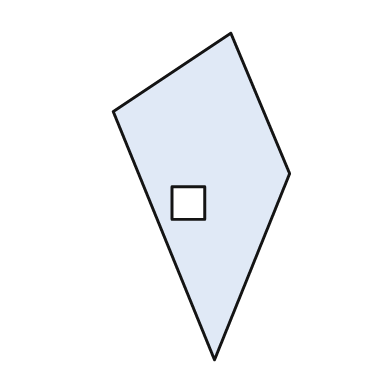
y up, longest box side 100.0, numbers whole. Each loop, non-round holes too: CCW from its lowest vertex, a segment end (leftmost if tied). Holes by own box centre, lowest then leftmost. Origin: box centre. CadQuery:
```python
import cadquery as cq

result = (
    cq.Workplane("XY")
    .moveTo(4.0, -50.0)
    .lineTo(27.0, 7.0)
    .lineTo(9.0, 50.0)
    .lineTo(-27.0, 26.0)
    .close()
    .moveTo(-9.0, -7.0)
    .lineTo(1.0, -7.0)
    .lineTo(1.0, 3.0)
    .lineTo(-9.0, 3.0)
    .close()
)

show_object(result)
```